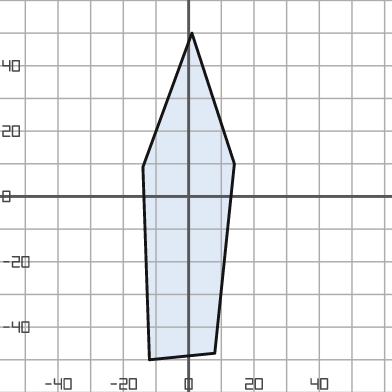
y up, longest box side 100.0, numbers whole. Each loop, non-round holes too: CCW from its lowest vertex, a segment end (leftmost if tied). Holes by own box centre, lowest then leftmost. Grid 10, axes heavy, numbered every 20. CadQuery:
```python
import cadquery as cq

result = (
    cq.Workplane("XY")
    .moveTo(-12.0, -50.0)
    .lineTo(8.0, -48.0)
    .lineTo(14.0, 10.0)
    .lineTo(1.0, 50.0)
    .lineTo(-14.0, 9.0)
    .close()
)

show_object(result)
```